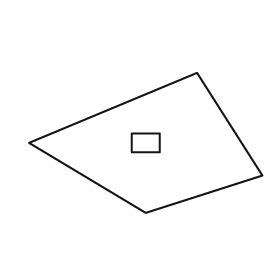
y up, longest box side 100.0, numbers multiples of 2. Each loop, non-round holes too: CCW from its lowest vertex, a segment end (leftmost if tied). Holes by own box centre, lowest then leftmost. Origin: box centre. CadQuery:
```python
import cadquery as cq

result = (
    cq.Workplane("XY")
    .moveTo(0.0, -30.0)
    .lineTo(50.0, -14.0)
    .lineTo(22.0, 30.0)
    .lineTo(-50.0, 0.0)
    .close()
    .moveTo(-6.0, -4.0)
    .lineTo(6.0, -4.0)
    .lineTo(6.0, 4.0)
    .lineTo(-6.0, 4.0)
    .close()
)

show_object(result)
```